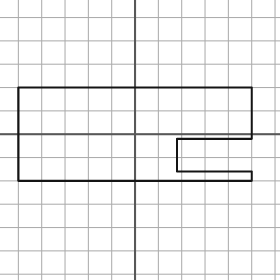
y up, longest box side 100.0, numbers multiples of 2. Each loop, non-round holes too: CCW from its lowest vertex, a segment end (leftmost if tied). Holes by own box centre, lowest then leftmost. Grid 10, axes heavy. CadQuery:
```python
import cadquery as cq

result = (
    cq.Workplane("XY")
    .moveTo(-50.0, -20.0)
    .lineTo(50.0, -20.0)
    .lineTo(50.0, -16.0)
    .lineTo(18.0, -16.0)
    .lineTo(18.0, -2.0)
    .lineTo(50.0, -2.0)
    .lineTo(50.0, 20.0)
    .lineTo(-50.0, 20.0)
    .close()
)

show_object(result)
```